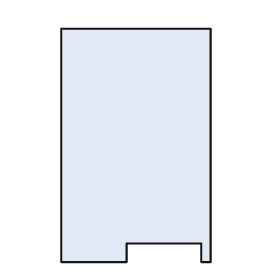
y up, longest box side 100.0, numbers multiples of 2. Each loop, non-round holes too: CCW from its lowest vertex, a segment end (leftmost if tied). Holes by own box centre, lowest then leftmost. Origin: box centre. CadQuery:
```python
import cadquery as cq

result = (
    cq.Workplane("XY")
    .moveTo(-32.0, -50.0)
    .lineTo(-4.0, -50.0)
    .lineTo(-4.0, -42.0)
    .lineTo(28.0, -42.0)
    .lineTo(28.0, -50.0)
    .lineTo(32.0, -50.0)
    .lineTo(32.0, 50.0)
    .lineTo(-32.0, 50.0)
    .close()
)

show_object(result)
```